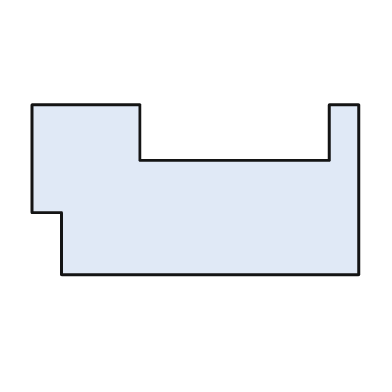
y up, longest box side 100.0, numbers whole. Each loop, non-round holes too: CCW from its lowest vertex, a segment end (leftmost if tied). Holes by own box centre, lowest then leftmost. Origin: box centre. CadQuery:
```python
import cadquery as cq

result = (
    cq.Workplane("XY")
    .moveTo(-41.0, -26.0)
    .lineTo(50.0, -26.0)
    .lineTo(50.0, 26.0)
    .lineTo(41.0, 26.0)
    .lineTo(41.0, 9.0)
    .lineTo(-17.0, 9.0)
    .lineTo(-17.0, 26.0)
    .lineTo(-50.0, 26.0)
    .lineTo(-50.0, -7.0)
    .lineTo(-41.0, -7.0)
    .close()
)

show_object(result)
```